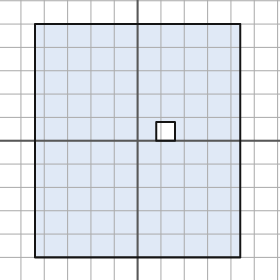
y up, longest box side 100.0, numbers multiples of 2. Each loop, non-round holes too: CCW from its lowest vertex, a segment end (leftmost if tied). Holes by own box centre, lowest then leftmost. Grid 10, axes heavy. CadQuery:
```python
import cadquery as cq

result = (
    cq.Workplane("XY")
    .moveTo(-44.0, -50.0)
    .lineTo(44.0, -50.0)
    .lineTo(44.0, 50.0)
    .lineTo(-44.0, 50.0)
    .close()
    .moveTo(8.0, 0.0)
    .lineTo(16.0, 0.0)
    .lineTo(16.0, 8.0)
    .lineTo(8.0, 8.0)
    .close()
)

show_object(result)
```